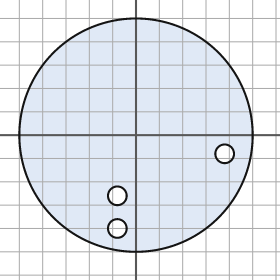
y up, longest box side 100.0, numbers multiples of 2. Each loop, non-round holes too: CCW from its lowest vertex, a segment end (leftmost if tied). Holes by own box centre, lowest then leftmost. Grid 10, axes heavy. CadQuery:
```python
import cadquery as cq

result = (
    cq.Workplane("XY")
    .moveTo(0.0, 0.0)
    .circle(50.0)
    .moveTo(-8.0, -40.0)
    .circle(4.0)
    .moveTo(-8.0, -26.0)
    .circle(4.0)
    .moveTo(38.0, -8.0)
    .circle(4.0)
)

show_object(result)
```